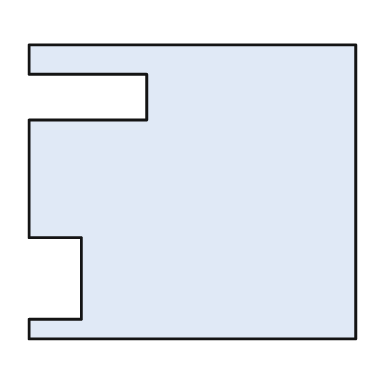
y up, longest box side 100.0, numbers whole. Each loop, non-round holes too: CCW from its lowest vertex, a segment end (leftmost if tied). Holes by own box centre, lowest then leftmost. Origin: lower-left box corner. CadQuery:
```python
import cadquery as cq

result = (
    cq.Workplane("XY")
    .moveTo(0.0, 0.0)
    .lineTo(100.0, 0.0)
    .lineTo(100.0, 90.0)
    .lineTo(0.0, 90.0)
    .lineTo(0.0, 81.0)
    .lineTo(36.0, 81.0)
    .lineTo(36.0, 67.0)
    .lineTo(0.0, 67.0)
    .lineTo(0.0, 31.0)
    .lineTo(16.0, 31.0)
    .lineTo(16.0, 6.0)
    .lineTo(0.0, 6.0)
    .close()
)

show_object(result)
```